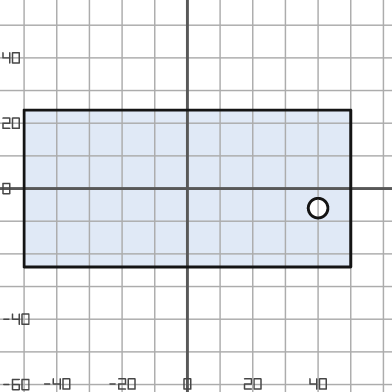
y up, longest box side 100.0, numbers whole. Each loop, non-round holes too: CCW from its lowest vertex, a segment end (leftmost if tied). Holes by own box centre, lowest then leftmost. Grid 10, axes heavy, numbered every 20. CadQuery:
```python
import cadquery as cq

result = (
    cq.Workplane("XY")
    .moveTo(-50.0, -24.0)
    .lineTo(50.0, -24.0)
    .lineTo(50.0, 24.0)
    .lineTo(-50.0, 24.0)
    .close()
    .moveTo(40.0, -6.0)
    .circle(3.0)
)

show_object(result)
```